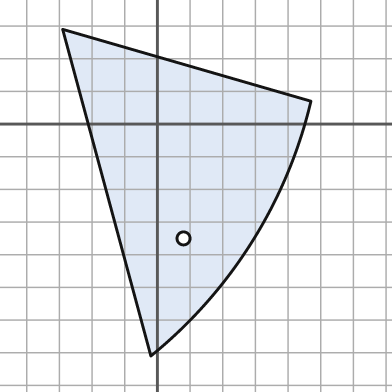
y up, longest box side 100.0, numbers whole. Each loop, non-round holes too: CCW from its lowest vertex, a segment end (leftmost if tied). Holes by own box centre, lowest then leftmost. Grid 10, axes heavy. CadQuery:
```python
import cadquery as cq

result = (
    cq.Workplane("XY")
    .moveTo(-2.0, -71.0)
    .threePointArc((29.0, -36.0), (47.0, 7.0))
    .lineTo(-29.0, 29.0)
    .close()
    .moveTo(8.0, -35.0)
    .circle(2.0)
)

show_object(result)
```